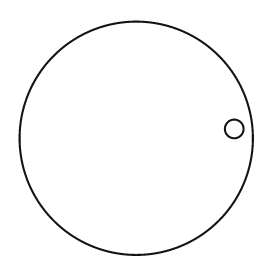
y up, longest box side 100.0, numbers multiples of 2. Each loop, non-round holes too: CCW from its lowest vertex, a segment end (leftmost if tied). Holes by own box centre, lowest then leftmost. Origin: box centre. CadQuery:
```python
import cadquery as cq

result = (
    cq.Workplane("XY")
    .moveTo(0.0, 0.0)
    .circle(50.0)
    .moveTo(42.0, 4.0)
    .circle(4.0)
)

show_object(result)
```